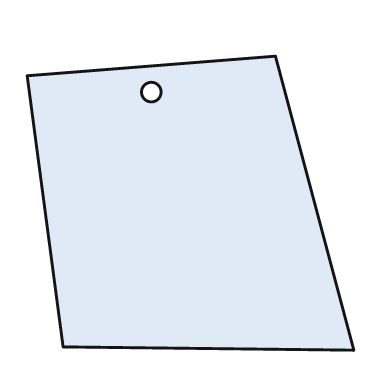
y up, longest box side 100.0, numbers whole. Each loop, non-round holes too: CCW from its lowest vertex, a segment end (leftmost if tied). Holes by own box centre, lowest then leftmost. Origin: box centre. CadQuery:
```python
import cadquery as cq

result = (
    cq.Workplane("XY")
    .moveTo(50.0, -45.0)
    .lineTo(26.0, 45.0)
    .lineTo(-50.0, 39.0)
    .lineTo(-39.0, -44.0)
    .close()
    .moveTo(-12.0, 34.0)
    .circle(3.0)
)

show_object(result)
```